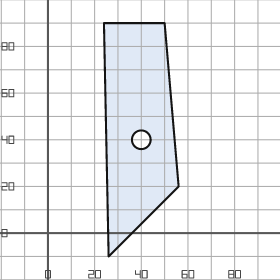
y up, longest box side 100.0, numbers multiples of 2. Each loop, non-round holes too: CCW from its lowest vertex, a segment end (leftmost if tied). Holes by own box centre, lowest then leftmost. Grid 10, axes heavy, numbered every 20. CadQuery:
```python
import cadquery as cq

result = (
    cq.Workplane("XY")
    .moveTo(26.0, -10.0)
    .lineTo(56.0, 20.0)
    .lineTo(50.0, 90.0)
    .lineTo(24.0, 90.0)
    .close()
    .moveTo(40.0, 40.0)
    .circle(4.0)
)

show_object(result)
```